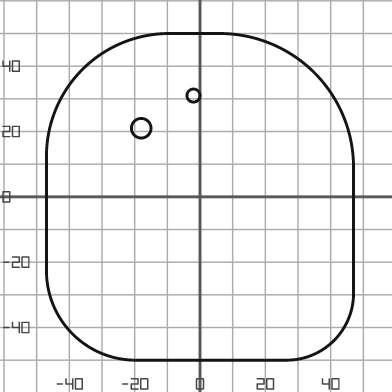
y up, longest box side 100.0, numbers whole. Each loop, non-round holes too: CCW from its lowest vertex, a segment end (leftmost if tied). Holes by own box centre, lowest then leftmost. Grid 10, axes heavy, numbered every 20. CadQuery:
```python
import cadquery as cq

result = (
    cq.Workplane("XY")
    .moveTo(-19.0, -50.0)
    .lineTo(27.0, -50.0)
    .threePointArc((41.0, -44.0), (47.0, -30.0))
    .lineTo(47.0, 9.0)
    .threePointArc((35.0, 38.0), (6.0, 50.0))
    .lineTo(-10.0, 50.0)
    .threePointArc((-36.0, 39.0), (-47.0, 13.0))
    .lineTo(-47.0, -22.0)
    .threePointArc((-39.0, -42.0), (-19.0, -50.0))
    .close()
    .moveTo(-18.0, 21.0)
    .circle(3.0)
    .moveTo(-2.0, 31.0)
    .circle(2.0)
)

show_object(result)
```